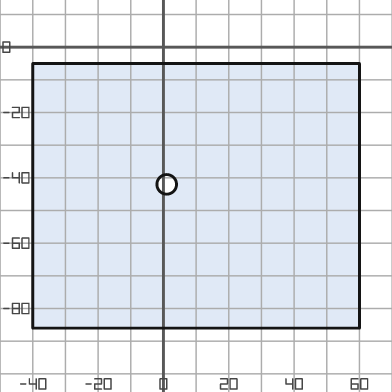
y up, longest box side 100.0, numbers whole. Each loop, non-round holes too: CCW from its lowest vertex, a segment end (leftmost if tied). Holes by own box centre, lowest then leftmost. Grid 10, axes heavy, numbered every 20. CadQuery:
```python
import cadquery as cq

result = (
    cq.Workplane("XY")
    .moveTo(-40.0, -86.0)
    .lineTo(60.0, -86.0)
    .lineTo(60.0, -5.0)
    .lineTo(-40.0, -5.0)
    .close()
    .moveTo(1.0, -42.0)
    .circle(3.0)
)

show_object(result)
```